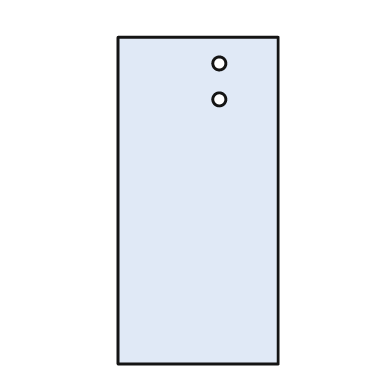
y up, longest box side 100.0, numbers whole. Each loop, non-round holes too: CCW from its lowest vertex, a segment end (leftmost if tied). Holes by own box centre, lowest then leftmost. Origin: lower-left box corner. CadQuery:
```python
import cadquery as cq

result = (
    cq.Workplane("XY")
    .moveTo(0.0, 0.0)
    .lineTo(49.0, 0.0)
    .lineTo(49.0, 100.0)
    .lineTo(0.0, 100.0)
    .close()
    .moveTo(31.0, 81.0)
    .circle(2.0)
    .moveTo(31.0, 92.0)
    .circle(2.0)
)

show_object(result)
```